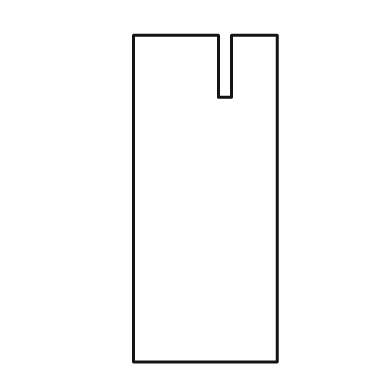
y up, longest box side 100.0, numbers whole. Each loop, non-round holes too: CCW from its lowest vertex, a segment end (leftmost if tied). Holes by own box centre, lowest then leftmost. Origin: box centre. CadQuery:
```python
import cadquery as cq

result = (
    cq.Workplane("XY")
    .moveTo(-22.0, -50.0)
    .lineTo(22.0, -50.0)
    .lineTo(22.0, 50.0)
    .lineTo(8.0, 50.0)
    .lineTo(8.0, 31.0)
    .lineTo(4.0, 31.0)
    .lineTo(4.0, 50.0)
    .lineTo(-22.0, 50.0)
    .close()
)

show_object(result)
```